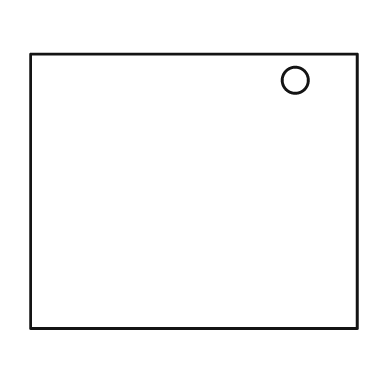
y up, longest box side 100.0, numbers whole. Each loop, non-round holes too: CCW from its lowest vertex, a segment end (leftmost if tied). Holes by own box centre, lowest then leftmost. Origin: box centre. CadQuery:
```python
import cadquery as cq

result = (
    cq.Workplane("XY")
    .moveTo(-50.0, -42.0)
    .lineTo(50.0, -42.0)
    .lineTo(50.0, 42.0)
    .lineTo(-50.0, 42.0)
    .close()
    .moveTo(31.0, 34.0)
    .circle(4.0)
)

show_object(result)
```